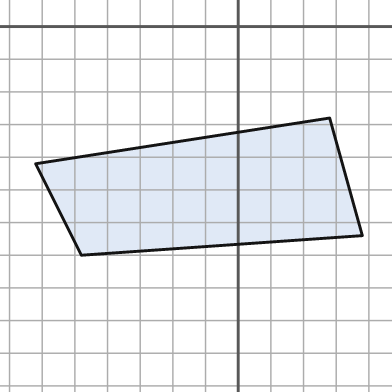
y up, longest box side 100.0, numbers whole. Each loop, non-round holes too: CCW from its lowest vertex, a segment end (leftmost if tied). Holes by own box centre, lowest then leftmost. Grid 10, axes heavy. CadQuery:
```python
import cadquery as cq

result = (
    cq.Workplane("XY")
    .moveTo(-48.0, -70.0)
    .lineTo(38.0, -64.0)
    .lineTo(28.0, -28.0)
    .lineTo(-62.0, -42.0)
    .close()
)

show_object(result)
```